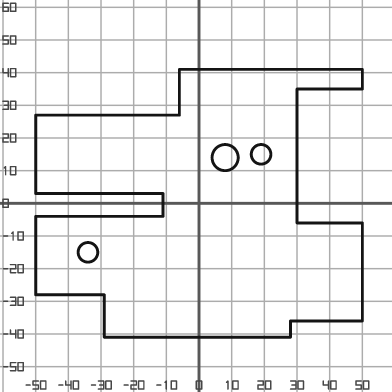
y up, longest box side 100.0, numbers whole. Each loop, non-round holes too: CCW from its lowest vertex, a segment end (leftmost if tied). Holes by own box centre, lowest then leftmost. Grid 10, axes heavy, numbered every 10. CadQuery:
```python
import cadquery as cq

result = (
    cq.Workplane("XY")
    .moveTo(-29.0, -41.0)
    .lineTo(28.0, -41.0)
    .lineTo(28.0, -36.0)
    .lineTo(50.0, -36.0)
    .lineTo(50.0, -6.0)
    .lineTo(30.0, -6.0)
    .lineTo(30.0, 35.0)
    .lineTo(50.0, 35.0)
    .lineTo(50.0, 41.0)
    .lineTo(-6.0, 41.0)
    .lineTo(-6.0, 27.0)
    .lineTo(-50.0, 27.0)
    .lineTo(-50.0, 3.0)
    .lineTo(-11.0, 3.0)
    .lineTo(-11.0, -4.0)
    .lineTo(-50.0, -4.0)
    .lineTo(-50.0, -28.0)
    .lineTo(-29.0, -28.0)
    .close()
    .moveTo(-34.0, -15.0)
    .circle(3.0)
    .moveTo(8.0, 14.0)
    .circle(4.0)
    .moveTo(19.0, 15.0)
    .circle(3.0)
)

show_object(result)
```